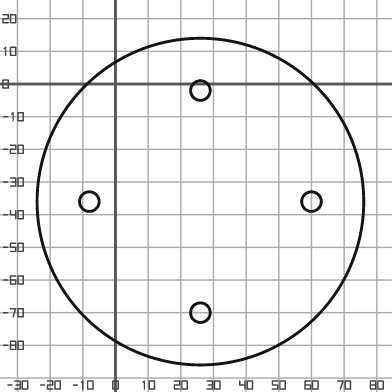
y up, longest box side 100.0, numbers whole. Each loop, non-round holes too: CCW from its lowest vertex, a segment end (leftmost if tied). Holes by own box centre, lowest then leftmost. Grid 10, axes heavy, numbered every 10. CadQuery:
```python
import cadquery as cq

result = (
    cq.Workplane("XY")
    .moveTo(26.0, -36.0)
    .circle(50.0)
    .moveTo(26.0, -70.0)
    .circle(3.0)
    .moveTo(-8.0, -36.0)
    .circle(3.0)
    .moveTo(60.0, -36.0)
    .circle(3.0)
    .moveTo(26.0, -2.0)
    .circle(3.0)
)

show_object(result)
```